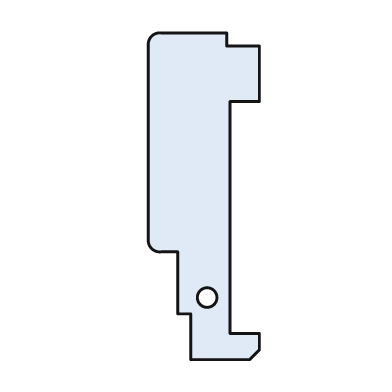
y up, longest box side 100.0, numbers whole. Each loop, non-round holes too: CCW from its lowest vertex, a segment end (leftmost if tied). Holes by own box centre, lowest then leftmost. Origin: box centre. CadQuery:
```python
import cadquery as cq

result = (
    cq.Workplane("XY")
    .moveTo(-4.0, -50.0)
    .lineTo(14.0, -50.0)
    .lineTo(17.0, -47.0)
    .lineTo(17.0, -42.0)
    .lineTo(8.0, -42.0)
    .lineTo(8.0, 29.0)
    .lineTo(17.0, 29.0)
    .lineTo(17.0, 46.0)
    .lineTo(7.0, 46.0)
    .lineTo(7.0, 50.0)
    .lineTo(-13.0, 50.0)
    .threePointArc((-16.0, 49.0), (-17.0, 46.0))
    .lineTo(-17.0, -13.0)
    .threePointArc((-16.0, -16.0), (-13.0, -17.0))
    .lineTo(-8.0, -17.0)
    .lineTo(-8.0, -36.0)
    .lineTo(-4.0, -36.0)
    .close()
    .moveTo(1.0, -31.0)
    .circle(3.0)
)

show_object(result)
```